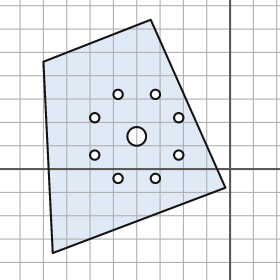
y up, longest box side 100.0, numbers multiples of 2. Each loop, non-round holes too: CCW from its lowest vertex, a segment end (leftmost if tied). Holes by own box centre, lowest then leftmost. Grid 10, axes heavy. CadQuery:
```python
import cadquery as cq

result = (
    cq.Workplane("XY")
    .moveTo(-76.0, -36.0)
    .lineTo(-2.0, -8.0)
    .lineTo(-34.0, 64.0)
    .lineTo(-80.0, 46.0)
    .close()
    .moveTo(-48.0, -4.0)
    .circle(2.0)
    .moveTo(-32.0, -4.0)
    .circle(2.0)
    .moveTo(-58.0, 6.0)
    .circle(2.0)
    .moveTo(-22.0, 6.0)
    .circle(2.0)
    .moveTo(-40.0, 14.0)
    .circle(4.0)
    .moveTo(-58.0, 22.0)
    .circle(2.0)
    .moveTo(-22.0, 22.0)
    .circle(2.0)
    .moveTo(-48.0, 32.0)
    .circle(2.0)
    .moveTo(-32.0, 32.0)
    .circle(2.0)
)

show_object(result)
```